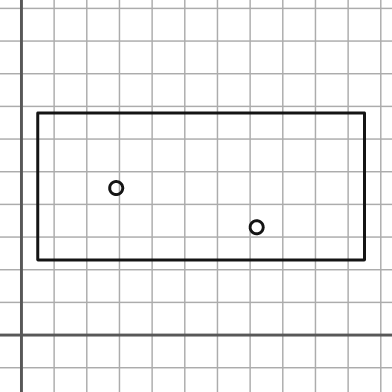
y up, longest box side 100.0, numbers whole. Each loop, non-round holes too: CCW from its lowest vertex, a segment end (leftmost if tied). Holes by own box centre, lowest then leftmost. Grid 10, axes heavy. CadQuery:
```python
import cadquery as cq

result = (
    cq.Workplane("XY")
    .moveTo(5.0, 23.0)
    .lineTo(105.0, 23.0)
    .lineTo(105.0, 68.0)
    .lineTo(5.0, 68.0)
    .close()
    .moveTo(72.0, 33.0)
    .circle(2.0)
    .moveTo(29.0, 45.0)
    .circle(2.0)
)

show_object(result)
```